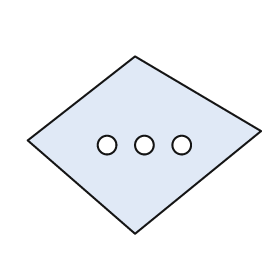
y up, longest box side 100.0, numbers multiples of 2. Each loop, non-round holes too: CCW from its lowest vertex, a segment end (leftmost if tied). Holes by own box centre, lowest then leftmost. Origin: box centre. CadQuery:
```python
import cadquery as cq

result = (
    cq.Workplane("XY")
    .moveTo(-4.0, -38.0)
    .lineTo(50.0, 6.0)
    .lineTo(-4.0, 38.0)
    .lineTo(-50.0, 2.0)
    .close()
    .moveTo(-16.0, 0.0)
    .circle(4.0)
    .moveTo(0.0, 0.0)
    .circle(4.0)
    .moveTo(16.0, 0.0)
    .circle(4.0)
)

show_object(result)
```